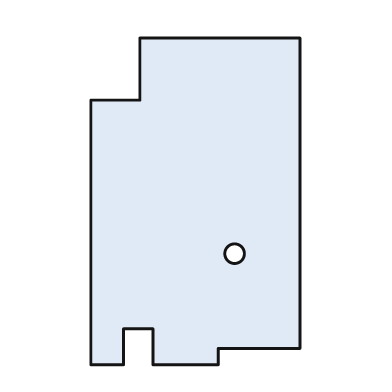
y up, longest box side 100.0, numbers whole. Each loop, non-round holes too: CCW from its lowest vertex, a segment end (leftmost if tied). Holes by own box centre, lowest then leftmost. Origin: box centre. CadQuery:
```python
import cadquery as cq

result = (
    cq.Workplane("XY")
    .moveTo(-32.0, -50.0)
    .lineTo(-22.0, -50.0)
    .lineTo(-22.0, -39.0)
    .lineTo(-13.0, -39.0)
    .lineTo(-13.0, -50.0)
    .lineTo(7.0, -50.0)
    .lineTo(7.0, -45.0)
    .lineTo(32.0, -45.0)
    .lineTo(32.0, 50.0)
    .lineTo(-17.0, 50.0)
    .lineTo(-17.0, 31.0)
    .lineTo(-32.0, 31.0)
    .close()
    .moveTo(12.0, -16.0)
    .circle(3.0)
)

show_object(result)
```